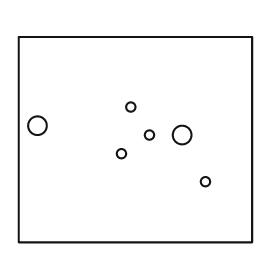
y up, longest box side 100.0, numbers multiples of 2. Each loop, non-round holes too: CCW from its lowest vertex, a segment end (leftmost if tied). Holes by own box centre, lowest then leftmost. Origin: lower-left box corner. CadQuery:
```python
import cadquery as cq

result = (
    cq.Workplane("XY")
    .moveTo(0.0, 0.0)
    .lineTo(100.0, 0.0)
    .lineTo(100.0, 88.0)
    .lineTo(0.0, 88.0)
    .close()
    .moveTo(80.0, 26.0)
    .circle(2.0)
    .moveTo(44.0, 38.0)
    .circle(2.0)
    .moveTo(56.0, 46.0)
    .circle(2.0)
    .moveTo(70.0, 46.0)
    .circle(4.0)
    .moveTo(8.0, 50.0)
    .circle(4.0)
    .moveTo(48.0, 58.0)
    .circle(2.0)
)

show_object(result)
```